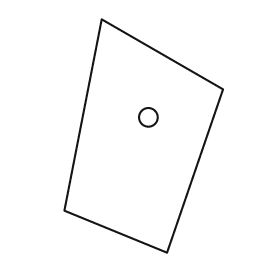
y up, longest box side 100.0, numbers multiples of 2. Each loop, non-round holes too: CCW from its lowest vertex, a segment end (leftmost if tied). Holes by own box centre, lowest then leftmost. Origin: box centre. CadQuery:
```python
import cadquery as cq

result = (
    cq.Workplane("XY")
    .moveTo(10.0, -50.0)
    .lineTo(34.0, 20.0)
    .lineTo(-18.0, 50.0)
    .lineTo(-34.0, -32.0)
    .close()
    .moveTo(2.0, 8.0)
    .circle(4.0)
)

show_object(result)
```